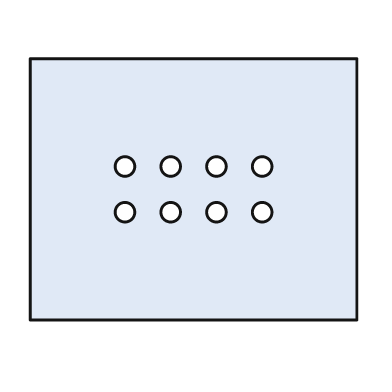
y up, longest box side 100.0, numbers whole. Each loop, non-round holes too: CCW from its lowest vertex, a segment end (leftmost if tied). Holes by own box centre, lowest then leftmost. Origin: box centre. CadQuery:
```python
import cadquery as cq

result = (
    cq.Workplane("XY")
    .moveTo(-50.0, -40.0)
    .lineTo(50.0, -40.0)
    .lineTo(50.0, 40.0)
    .lineTo(-50.0, 40.0)
    .close()
    .moveTo(-21.0, -7.0)
    .circle(3.0)
    .moveTo(-7.0, -7.0)
    .circle(3.0)
    .moveTo(7.0, -7.0)
    .circle(3.0)
    .moveTo(21.0, -7.0)
    .circle(3.0)
    .moveTo(-21.0, 7.0)
    .circle(3.0)
    .moveTo(-7.0, 7.0)
    .circle(3.0)
    .moveTo(7.0, 7.0)
    .circle(3.0)
    .moveTo(21.0, 7.0)
    .circle(3.0)
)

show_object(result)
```